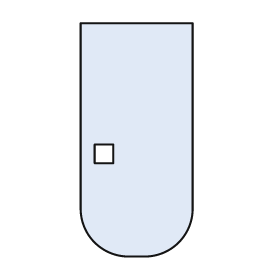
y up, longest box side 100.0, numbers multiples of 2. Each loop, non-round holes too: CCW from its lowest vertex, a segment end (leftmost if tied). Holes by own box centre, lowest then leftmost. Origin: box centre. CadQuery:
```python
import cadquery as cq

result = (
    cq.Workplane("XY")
    .moveTo(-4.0, -50.0)
    .lineTo(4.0, -50.0)
    .threePointArc((18.0, -44.0), (24.0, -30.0))
    .lineTo(24.0, 50.0)
    .lineTo(-24.0, 50.0)
    .lineTo(-24.0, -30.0)
    .threePointArc((-18.0, -44.0), (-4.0, -50.0))
    .close()
    .moveTo(-18.0, -10.0)
    .lineTo(-10.0, -10.0)
    .lineTo(-10.0, -2.0)
    .lineTo(-18.0, -2.0)
    .close()
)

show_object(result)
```